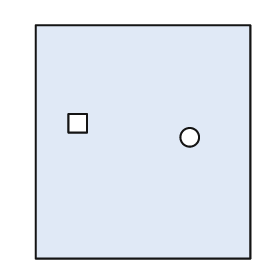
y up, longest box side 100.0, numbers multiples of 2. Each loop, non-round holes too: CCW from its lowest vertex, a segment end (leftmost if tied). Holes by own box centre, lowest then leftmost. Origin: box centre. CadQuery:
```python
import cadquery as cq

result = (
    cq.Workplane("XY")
    .moveTo(-46.0, -50.0)
    .lineTo(46.0, -50.0)
    .lineTo(46.0, 50.0)
    .lineTo(-46.0, 50.0)
    .close()
    .moveTo(20.0, 2.0)
    .circle(4.0)
    .moveTo(-32.0, 4.0)
    .lineTo(-24.0, 4.0)
    .lineTo(-24.0, 12.0)
    .lineTo(-32.0, 12.0)
    .close()
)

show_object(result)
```